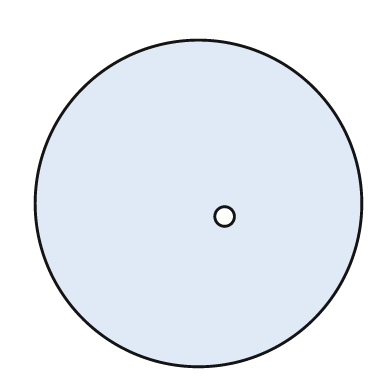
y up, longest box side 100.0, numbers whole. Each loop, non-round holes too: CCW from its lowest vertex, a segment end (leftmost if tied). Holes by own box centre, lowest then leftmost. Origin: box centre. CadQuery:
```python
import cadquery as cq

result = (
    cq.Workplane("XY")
    .moveTo(0.0, 0.0)
    .circle(50.0)
    .moveTo(8.0, -4.0)
    .circle(3.0)
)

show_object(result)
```